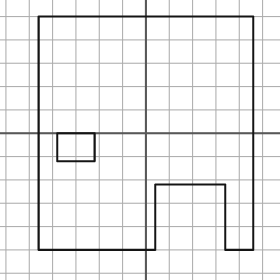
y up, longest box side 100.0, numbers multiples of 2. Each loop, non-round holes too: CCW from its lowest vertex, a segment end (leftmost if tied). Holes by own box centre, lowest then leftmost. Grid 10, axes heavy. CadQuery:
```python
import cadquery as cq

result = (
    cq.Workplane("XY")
    .moveTo(-46.0, -50.0)
    .lineTo(4.0, -50.0)
    .lineTo(4.0, -22.0)
    .lineTo(34.0, -22.0)
    .lineTo(34.0, -50.0)
    .lineTo(46.0, -50.0)
    .lineTo(46.0, 50.0)
    .lineTo(-46.0, 50.0)
    .close()
    .moveTo(-38.0, -12.0)
    .lineTo(-22.0, -12.0)
    .lineTo(-22.0, 0.0)
    .lineTo(-38.0, 0.0)
    .close()
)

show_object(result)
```